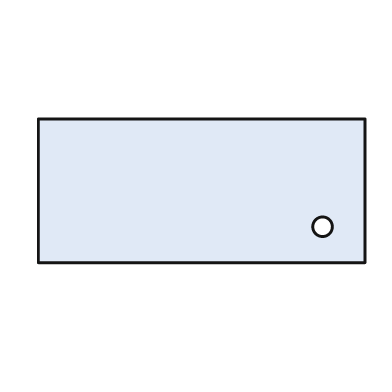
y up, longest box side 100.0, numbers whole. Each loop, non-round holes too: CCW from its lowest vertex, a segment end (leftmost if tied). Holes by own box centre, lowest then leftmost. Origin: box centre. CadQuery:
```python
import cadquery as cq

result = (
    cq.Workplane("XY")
    .moveTo(-50.0, -22.0)
    .lineTo(50.0, -22.0)
    .lineTo(50.0, 22.0)
    .lineTo(-50.0, 22.0)
    .close()
    .moveTo(37.0, -11.0)
    .circle(3.0)
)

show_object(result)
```